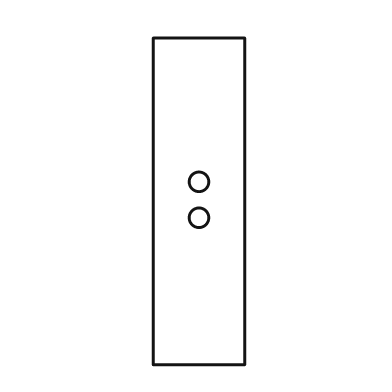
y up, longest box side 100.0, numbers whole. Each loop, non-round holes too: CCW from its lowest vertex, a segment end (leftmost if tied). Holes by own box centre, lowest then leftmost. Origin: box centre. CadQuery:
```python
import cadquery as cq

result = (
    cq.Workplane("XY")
    .moveTo(-14.0, -50.0)
    .lineTo(14.0, -50.0)
    .lineTo(14.0, 50.0)
    .lineTo(-14.0, 50.0)
    .close()
    .moveTo(0.0, -5.0)
    .circle(3.0)
    .moveTo(0.0, 6.0)
    .circle(3.0)
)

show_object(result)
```